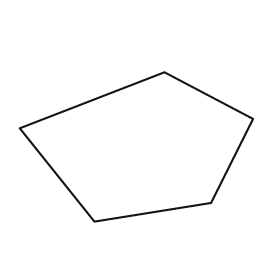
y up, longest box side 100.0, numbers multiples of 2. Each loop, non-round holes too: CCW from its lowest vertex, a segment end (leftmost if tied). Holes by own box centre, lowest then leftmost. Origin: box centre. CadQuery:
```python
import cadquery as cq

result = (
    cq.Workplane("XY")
    .moveTo(-18.0, -32.0)
    .lineTo(32.0, -24.0)
    .lineTo(50.0, 12.0)
    .lineTo(12.0, 32.0)
    .lineTo(-50.0, 8.0)
    .close()
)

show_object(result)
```